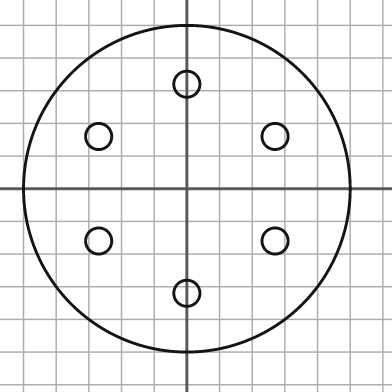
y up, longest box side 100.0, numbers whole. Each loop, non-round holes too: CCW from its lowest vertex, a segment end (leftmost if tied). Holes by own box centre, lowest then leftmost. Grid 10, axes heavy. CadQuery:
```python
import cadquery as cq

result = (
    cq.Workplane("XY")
    .moveTo(0.0, 0.0)
    .circle(50.0)
    .moveTo(0.0, -32.0)
    .circle(4.0)
    .moveTo(-27.0, -16.0)
    .circle(4.0)
    .moveTo(27.0, -16.0)
    .circle(4.0)
    .moveTo(-27.0, 16.0)
    .circle(4.0)
    .moveTo(27.0, 16.0)
    .circle(4.0)
    .moveTo(0.0, 32.0)
    .circle(4.0)
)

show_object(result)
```